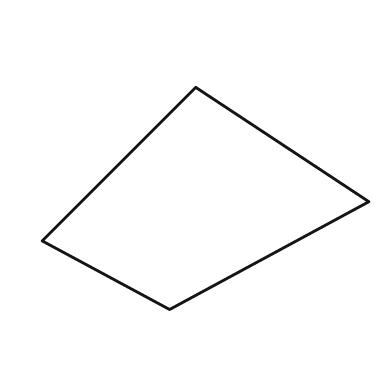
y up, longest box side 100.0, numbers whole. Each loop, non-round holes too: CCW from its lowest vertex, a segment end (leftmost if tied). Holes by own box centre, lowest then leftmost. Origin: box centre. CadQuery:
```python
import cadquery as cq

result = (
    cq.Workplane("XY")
    .moveTo(-11.0, -34.0)
    .lineTo(50.0, -1.0)
    .lineTo(-3.0, 34.0)
    .lineTo(-50.0, -13.0)
    .close()
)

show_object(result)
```